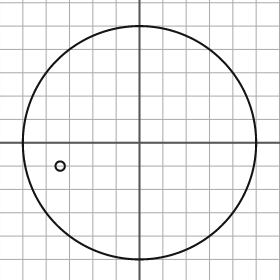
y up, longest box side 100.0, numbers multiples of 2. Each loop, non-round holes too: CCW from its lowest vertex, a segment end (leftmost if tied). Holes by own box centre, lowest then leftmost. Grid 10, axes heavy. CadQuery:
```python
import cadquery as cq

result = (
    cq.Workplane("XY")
    .moveTo(0.0, 0.0)
    .circle(50.0)
    .moveTo(-34.0, -10.0)
    .circle(2.0)
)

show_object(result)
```